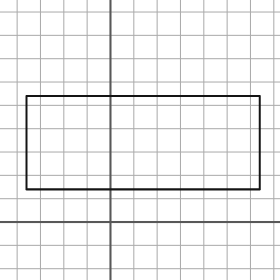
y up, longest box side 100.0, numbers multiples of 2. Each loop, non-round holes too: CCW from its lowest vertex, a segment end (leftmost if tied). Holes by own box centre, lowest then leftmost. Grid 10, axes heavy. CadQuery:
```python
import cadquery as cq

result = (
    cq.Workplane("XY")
    .moveTo(-36.0, 14.0)
    .lineTo(64.0, 14.0)
    .lineTo(64.0, 54.0)
    .lineTo(-36.0, 54.0)
    .close()
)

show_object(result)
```